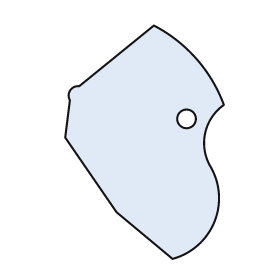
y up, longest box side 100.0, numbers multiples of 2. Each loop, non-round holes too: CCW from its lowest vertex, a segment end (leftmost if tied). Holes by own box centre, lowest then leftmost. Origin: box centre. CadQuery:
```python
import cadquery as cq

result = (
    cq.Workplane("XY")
    .moveTo(12.0, -50.0)
    .threePointArc((30.0, -34.0), (28.0, -10.0))
    .threePointArc((26.0, 4.0), (34.0, 16.0))
    .threePointArc((22.0, 36.0), (4.0, 50.0))
    .lineTo(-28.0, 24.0)
    .threePointArc((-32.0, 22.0), (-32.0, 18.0))
    .lineTo(-34.0, 2.0)
    .lineTo(-12.0, -30.0)
    .close()
    .moveTo(18.0, 10.0)
    .circle(4.0)
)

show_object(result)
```